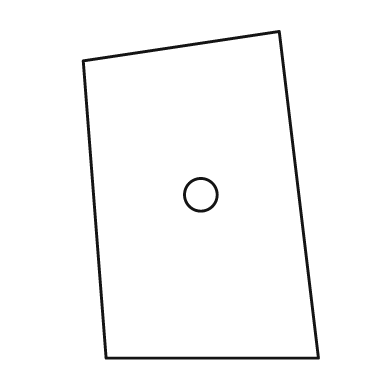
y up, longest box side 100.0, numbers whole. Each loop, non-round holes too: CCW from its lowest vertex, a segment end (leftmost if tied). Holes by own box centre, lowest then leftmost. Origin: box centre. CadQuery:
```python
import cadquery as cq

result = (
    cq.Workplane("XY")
    .moveTo(-29.0, -50.0)
    .lineTo(36.0, -50.0)
    .lineTo(24.0, 50.0)
    .lineTo(-36.0, 41.0)
    .close()
    .moveTo(0.0, 0.0)
    .circle(5.0)
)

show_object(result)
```